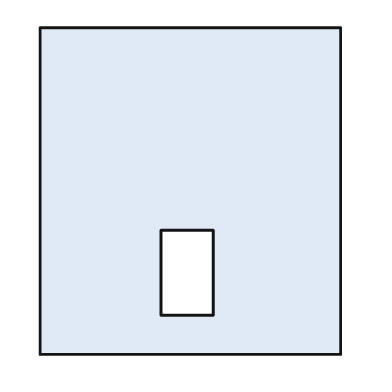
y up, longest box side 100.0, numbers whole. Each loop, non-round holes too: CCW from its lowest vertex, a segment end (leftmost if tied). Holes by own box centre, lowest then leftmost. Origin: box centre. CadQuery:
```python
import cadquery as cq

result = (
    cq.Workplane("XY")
    .moveTo(-46.0, -50.0)
    .lineTo(46.0, -50.0)
    .lineTo(46.0, 50.0)
    .lineTo(-46.0, 50.0)
    .close()
    .moveTo(-9.0, -38.0)
    .lineTo(7.0, -38.0)
    .lineTo(7.0, -12.0)
    .lineTo(-9.0, -12.0)
    .close()
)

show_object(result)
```